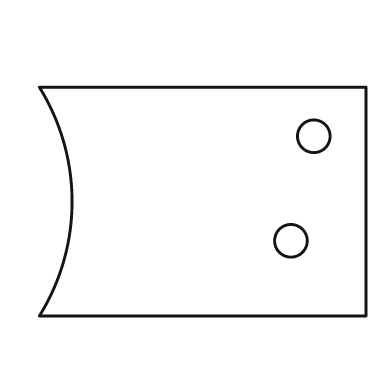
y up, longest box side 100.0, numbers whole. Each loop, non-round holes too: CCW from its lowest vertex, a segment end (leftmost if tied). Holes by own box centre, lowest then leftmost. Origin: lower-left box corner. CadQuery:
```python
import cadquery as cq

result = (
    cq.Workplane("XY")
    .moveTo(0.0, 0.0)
    .lineTo(100.0, 0.0)
    .lineTo(100.0, 70.0)
    .lineTo(0.0, 70.0)
    .threePointArc((10.0, 35.0), (0.0, 0.0))
    .close()
    .moveTo(77.0, 23.0)
    .circle(5.0)
    .moveTo(84.0, 55.0)
    .circle(5.0)
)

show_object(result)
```